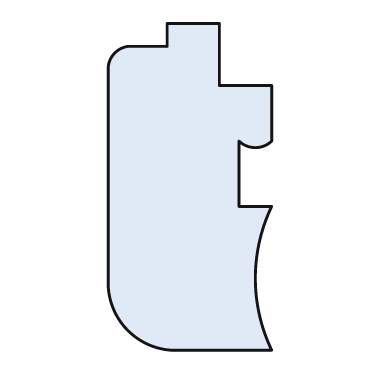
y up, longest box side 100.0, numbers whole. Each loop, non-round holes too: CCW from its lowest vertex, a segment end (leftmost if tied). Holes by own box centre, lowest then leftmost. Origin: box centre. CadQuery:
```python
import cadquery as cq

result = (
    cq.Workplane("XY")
    .moveTo(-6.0, -50.0)
    .lineTo(25.0, -50.0)
    .threePointArc((20.0, -28.0), (25.0, -6.0))
    .lineTo(15.0, -6.0)
    .lineTo(15.0, 14.0)
    .threePointArc((20.0, 12.0), (25.0, 14.0))
    .lineTo(25.0, 31.0)
    .lineTo(9.0, 31.0)
    .lineTo(9.0, 50.0)
    .lineTo(-7.0, 50.0)
    .lineTo(-7.0, 43.0)
    .lineTo(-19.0, 43.0)
    .threePointArc((-23.0, 41.0), (-25.0, 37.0))
    .lineTo(-25.0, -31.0)
    .threePointArc((-19.0, -44.0), (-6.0, -50.0))
    .close()
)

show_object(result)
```